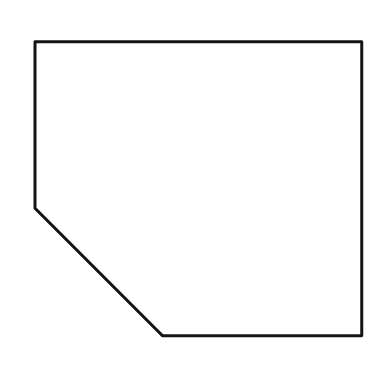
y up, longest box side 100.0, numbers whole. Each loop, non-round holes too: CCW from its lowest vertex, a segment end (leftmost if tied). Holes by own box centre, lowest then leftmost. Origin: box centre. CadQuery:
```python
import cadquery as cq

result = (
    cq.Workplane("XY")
    .moveTo(-11.0, -45.0)
    .lineTo(50.0, -45.0)
    .lineTo(50.0, 45.0)
    .lineTo(-50.0, 45.0)
    .lineTo(-50.0, -6.0)
    .close()
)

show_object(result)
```